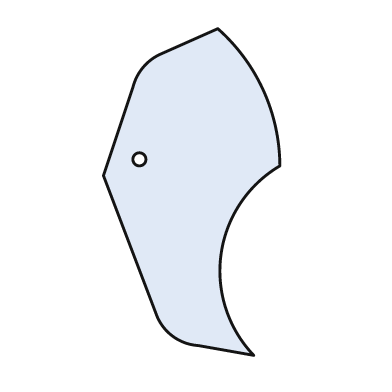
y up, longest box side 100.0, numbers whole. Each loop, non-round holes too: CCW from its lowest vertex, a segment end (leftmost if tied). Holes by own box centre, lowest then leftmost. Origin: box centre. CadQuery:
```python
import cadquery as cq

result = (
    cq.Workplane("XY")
    .moveTo(19.0, -50.0)
    .threePointArc((9.0, -19.0), (27.0, 8.0))
    .threePointArc((22.0, 31.0), (8.0, 50.0))
    .lineTo(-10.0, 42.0)
    .threePointArc((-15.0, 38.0), (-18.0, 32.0))
    .lineTo(-27.0, 5.0)
    .lineTo(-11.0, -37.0)
    .threePointArc((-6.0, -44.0), (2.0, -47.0))
    .close()
    .moveTo(-16.0, 10.0)
    .circle(2.0)
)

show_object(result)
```